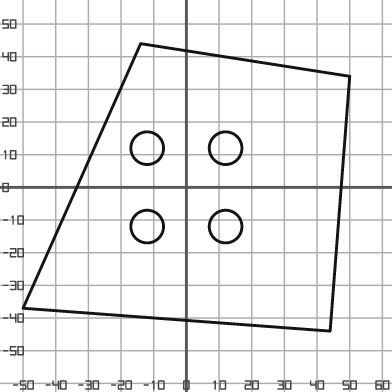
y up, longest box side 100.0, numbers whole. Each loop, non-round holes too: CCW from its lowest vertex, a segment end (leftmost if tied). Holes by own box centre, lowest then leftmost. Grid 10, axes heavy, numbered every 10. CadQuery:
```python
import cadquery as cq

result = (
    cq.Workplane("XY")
    .moveTo(44.0, -44.0)
    .lineTo(50.0, 34.0)
    .lineTo(-14.0, 44.0)
    .lineTo(-50.0, -37.0)
    .close()
    .moveTo(-12.0, -12.0)
    .circle(5.0)
    .moveTo(12.0, -12.0)
    .circle(5.0)
    .moveTo(-12.0, 12.0)
    .circle(5.0)
    .moveTo(12.0, 12.0)
    .circle(5.0)
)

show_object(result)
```